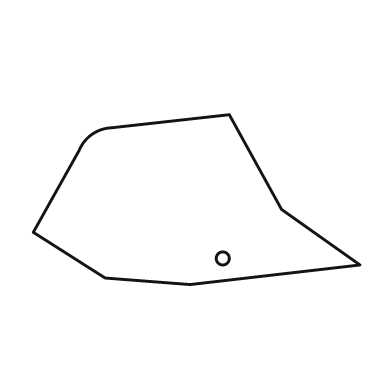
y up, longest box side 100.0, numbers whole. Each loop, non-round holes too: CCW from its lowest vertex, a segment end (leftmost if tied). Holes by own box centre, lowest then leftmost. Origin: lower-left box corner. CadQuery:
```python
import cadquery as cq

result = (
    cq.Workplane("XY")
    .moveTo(48.0, 0.0)
    .lineTo(100.0, 6.0)
    .lineTo(76.0, 23.0)
    .lineTo(60.0, 52.0)
    .lineTo(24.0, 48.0)
    .threePointArc((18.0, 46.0), (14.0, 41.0))
    .lineTo(0.0, 16.0)
    .lineTo(22.0, 2.0)
    .close()
    .moveTo(58.0, 8.0)
    .circle(2.0)
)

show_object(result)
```